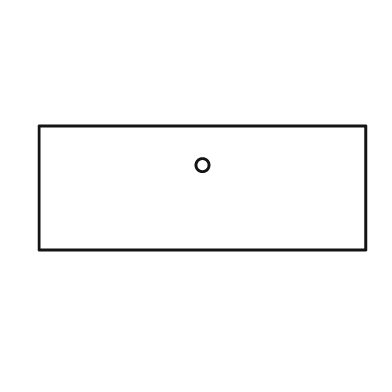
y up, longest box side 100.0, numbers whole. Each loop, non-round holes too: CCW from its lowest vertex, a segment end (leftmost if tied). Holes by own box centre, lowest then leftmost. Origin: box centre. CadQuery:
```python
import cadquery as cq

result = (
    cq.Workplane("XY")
    .moveTo(-50.0, -19.0)
    .lineTo(50.0, -19.0)
    .lineTo(50.0, 19.0)
    .lineTo(-50.0, 19.0)
    .close()
    .moveTo(0.0, 7.0)
    .circle(2.0)
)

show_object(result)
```